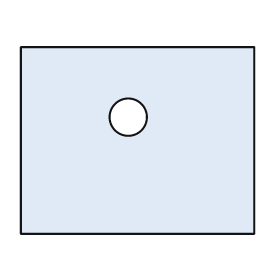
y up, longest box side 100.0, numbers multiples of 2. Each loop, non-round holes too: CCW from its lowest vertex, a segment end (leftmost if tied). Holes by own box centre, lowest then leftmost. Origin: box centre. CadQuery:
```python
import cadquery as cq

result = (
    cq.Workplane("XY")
    .moveTo(-50.0, -40.0)
    .lineTo(50.0, -40.0)
    .lineTo(50.0, 40.0)
    .lineTo(-50.0, 40.0)
    .close()
    .moveTo(-4.0, 10.0)
    .circle(8.0)
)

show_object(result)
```